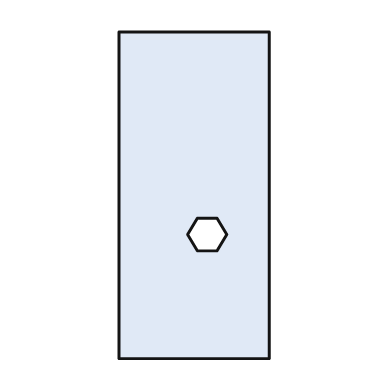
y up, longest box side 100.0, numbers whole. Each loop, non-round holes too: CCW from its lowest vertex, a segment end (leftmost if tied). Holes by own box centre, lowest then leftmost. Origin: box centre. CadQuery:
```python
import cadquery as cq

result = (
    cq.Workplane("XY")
    .moveTo(-23.0, -50.0)
    .lineTo(23.0, -50.0)
    .lineTo(23.0, 50.0)
    .lineTo(-23.0, 50.0)
    .close()
    .moveTo(1.0, -17.0)
    .lineTo(7.0, -17.0)
    .lineTo(10.0, -12.0)
    .lineTo(7.0, -7.0)
    .lineTo(1.0, -7.0)
    .lineTo(-2.0, -12.0)
    .close()
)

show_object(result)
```